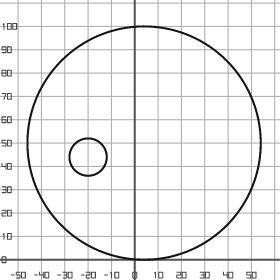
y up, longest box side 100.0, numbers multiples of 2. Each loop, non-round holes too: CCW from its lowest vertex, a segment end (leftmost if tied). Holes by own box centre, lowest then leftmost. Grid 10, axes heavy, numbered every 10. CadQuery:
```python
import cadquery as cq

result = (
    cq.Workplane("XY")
    .moveTo(4.0, 50.0)
    .circle(50.0)
    .moveTo(-20.0, 44.0)
    .circle(8.0)
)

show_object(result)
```